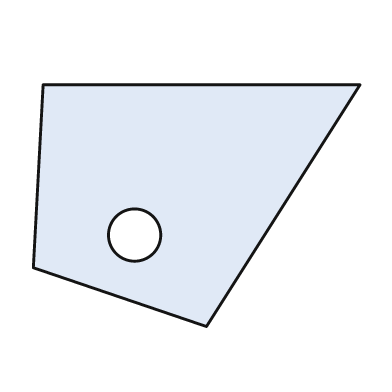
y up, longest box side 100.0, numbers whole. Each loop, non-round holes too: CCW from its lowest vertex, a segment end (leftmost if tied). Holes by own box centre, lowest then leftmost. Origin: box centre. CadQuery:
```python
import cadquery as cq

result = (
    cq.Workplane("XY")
    .moveTo(3.0, -37.0)
    .lineTo(50.0, 37.0)
    .lineTo(-47.0, 37.0)
    .lineTo(-50.0, -19.0)
    .close()
    .moveTo(-19.0, -9.0)
    .circle(8.0)
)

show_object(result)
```